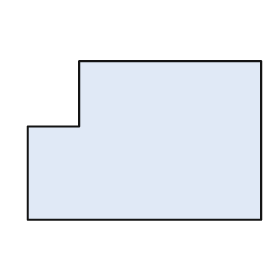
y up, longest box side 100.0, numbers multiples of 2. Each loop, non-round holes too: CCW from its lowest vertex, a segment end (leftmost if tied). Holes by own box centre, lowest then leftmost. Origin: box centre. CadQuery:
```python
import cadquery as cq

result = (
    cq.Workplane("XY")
    .moveTo(-50.0, -34.0)
    .lineTo(50.0, -34.0)
    .lineTo(50.0, 34.0)
    .lineTo(-28.0, 34.0)
    .lineTo(-28.0, 6.0)
    .lineTo(-50.0, 6.0)
    .close()
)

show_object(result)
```